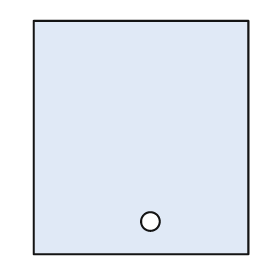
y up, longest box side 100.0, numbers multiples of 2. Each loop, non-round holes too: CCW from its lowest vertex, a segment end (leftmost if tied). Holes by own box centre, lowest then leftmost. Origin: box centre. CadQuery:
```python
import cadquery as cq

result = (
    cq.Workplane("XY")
    .moveTo(-46.0, -50.0)
    .lineTo(46.0, -50.0)
    .lineTo(46.0, 50.0)
    .lineTo(-46.0, 50.0)
    .close()
    .moveTo(4.0, -36.0)
    .circle(4.0)
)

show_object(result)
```